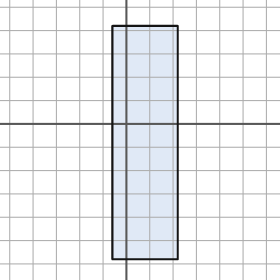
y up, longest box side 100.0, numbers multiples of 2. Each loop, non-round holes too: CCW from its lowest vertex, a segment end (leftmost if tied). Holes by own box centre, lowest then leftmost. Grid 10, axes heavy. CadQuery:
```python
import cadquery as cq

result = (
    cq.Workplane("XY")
    .moveTo(-6.0, -58.0)
    .lineTo(22.0, -58.0)
    .lineTo(22.0, 42.0)
    .lineTo(-6.0, 42.0)
    .close()
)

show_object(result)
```